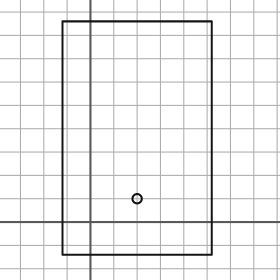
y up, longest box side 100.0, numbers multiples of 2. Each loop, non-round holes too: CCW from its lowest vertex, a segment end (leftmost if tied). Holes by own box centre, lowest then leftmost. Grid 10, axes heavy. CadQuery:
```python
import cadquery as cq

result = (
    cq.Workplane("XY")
    .moveTo(-12.0, -14.0)
    .lineTo(52.0, -14.0)
    .lineTo(52.0, 86.0)
    .lineTo(-12.0, 86.0)
    .close()
    .moveTo(20.0, 10.0)
    .circle(2.0)
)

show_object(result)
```